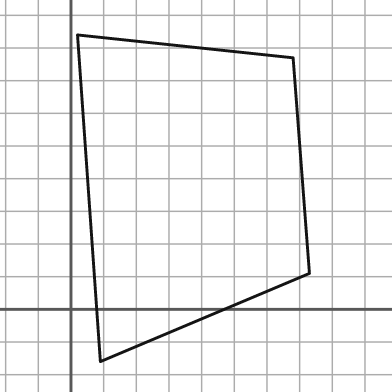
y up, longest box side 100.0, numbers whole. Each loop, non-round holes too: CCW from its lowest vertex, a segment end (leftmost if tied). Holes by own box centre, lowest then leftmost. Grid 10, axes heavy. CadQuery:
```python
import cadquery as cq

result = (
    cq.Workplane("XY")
    .moveTo(9.0, -16.0)
    .lineTo(73.0, 11.0)
    .lineTo(68.0, 77.0)
    .lineTo(2.0, 84.0)
    .close()
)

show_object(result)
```